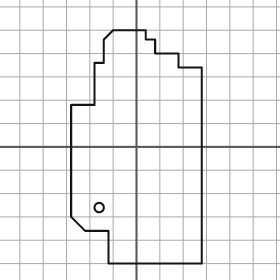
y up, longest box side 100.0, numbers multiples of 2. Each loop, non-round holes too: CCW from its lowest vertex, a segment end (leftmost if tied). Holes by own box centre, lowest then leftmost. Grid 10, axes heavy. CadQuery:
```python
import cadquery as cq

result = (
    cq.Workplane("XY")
    .moveTo(-12.0, -50.0)
    .lineTo(28.0, -50.0)
    .lineTo(28.0, 34.0)
    .lineTo(18.0, 34.0)
    .lineTo(18.0, 40.0)
    .lineTo(8.0, 40.0)
    .lineTo(8.0, 46.0)
    .lineTo(4.0, 46.0)
    .lineTo(4.0, 50.0)
    .lineTo(-10.0, 50.0)
    .lineTo(-14.0, 46.0)
    .lineTo(-14.0, 36.0)
    .lineTo(-18.0, 36.0)
    .lineTo(-18.0, 18.0)
    .lineTo(-28.0, 18.0)
    .lineTo(-28.0, -30.0)
    .lineTo(-22.0, -36.0)
    .lineTo(-12.0, -36.0)
    .close()
    .moveTo(-16.0, -26.0)
    .circle(2.0)
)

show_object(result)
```